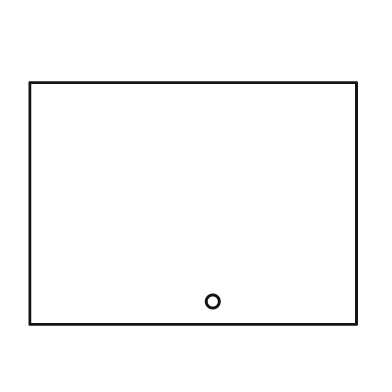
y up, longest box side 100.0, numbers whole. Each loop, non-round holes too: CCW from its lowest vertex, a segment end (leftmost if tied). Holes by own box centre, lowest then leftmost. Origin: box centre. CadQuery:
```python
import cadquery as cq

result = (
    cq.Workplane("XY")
    .moveTo(-50.0, -37.0)
    .lineTo(50.0, -37.0)
    .lineTo(50.0, 37.0)
    .lineTo(-50.0, 37.0)
    .close()
    .moveTo(6.0, -30.0)
    .circle(2.0)
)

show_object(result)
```